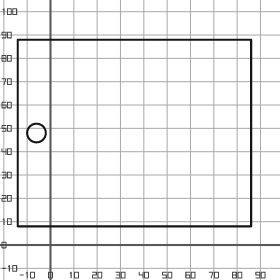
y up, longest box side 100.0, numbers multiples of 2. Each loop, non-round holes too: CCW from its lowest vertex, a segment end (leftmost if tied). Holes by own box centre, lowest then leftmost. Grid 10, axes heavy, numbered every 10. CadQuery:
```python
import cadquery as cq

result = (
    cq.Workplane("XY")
    .moveTo(-14.0, 8.0)
    .lineTo(86.0, 8.0)
    .lineTo(86.0, 88.0)
    .lineTo(-14.0, 88.0)
    .close()
    .moveTo(-6.0, 48.0)
    .circle(4.0)
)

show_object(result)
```